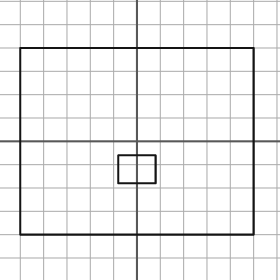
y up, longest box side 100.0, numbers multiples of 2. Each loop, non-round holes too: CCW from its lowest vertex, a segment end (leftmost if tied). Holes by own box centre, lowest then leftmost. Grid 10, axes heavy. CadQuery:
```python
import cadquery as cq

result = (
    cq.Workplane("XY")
    .moveTo(-50.0, -40.0)
    .lineTo(50.0, -40.0)
    .lineTo(50.0, 40.0)
    .lineTo(-50.0, 40.0)
    .close()
    .moveTo(-8.0, -18.0)
    .lineTo(8.0, -18.0)
    .lineTo(8.0, -6.0)
    .lineTo(-8.0, -6.0)
    .close()
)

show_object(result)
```